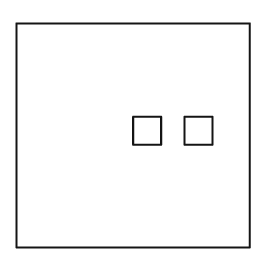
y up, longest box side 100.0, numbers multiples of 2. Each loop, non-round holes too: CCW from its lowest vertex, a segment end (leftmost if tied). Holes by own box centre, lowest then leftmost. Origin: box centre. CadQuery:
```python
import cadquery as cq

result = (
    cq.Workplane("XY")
    .moveTo(-50.0, -48.0)
    .lineTo(50.0, -48.0)
    .lineTo(50.0, 48.0)
    .lineTo(-50.0, 48.0)
    .close()
    .moveTo(0.0, -4.0)
    .lineTo(12.0, -4.0)
    .lineTo(12.0, 8.0)
    .lineTo(0.0, 8.0)
    .close()
    .moveTo(22.0, -4.0)
    .lineTo(34.0, -4.0)
    .lineTo(34.0, 8.0)
    .lineTo(22.0, 8.0)
    .close()
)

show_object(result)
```